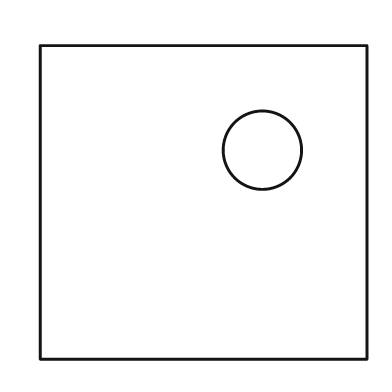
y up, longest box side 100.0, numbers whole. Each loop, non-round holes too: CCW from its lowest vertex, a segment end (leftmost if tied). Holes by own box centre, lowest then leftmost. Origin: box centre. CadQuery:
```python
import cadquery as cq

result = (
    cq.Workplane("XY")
    .moveTo(-50.0, -48.0)
    .lineTo(50.0, -48.0)
    .lineTo(50.0, 48.0)
    .lineTo(-50.0, 48.0)
    .close()
    .moveTo(18.0, 16.0)
    .circle(12.0)
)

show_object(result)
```